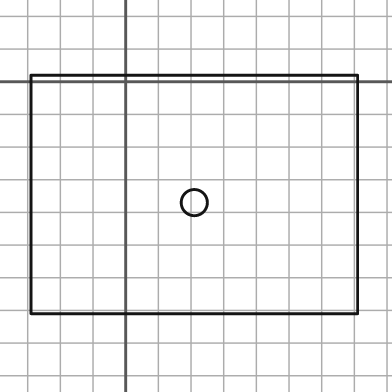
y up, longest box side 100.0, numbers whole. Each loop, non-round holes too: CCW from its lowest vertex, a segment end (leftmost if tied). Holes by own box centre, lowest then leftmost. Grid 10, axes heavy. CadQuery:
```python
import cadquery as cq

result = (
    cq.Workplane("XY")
    .moveTo(-29.0, -71.0)
    .lineTo(71.0, -71.0)
    .lineTo(71.0, 2.0)
    .lineTo(-29.0, 2.0)
    .close()
    .moveTo(21.0, -37.0)
    .circle(4.0)
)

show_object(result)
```